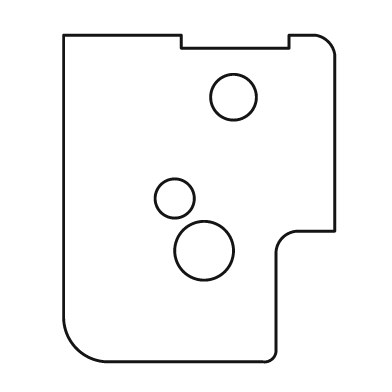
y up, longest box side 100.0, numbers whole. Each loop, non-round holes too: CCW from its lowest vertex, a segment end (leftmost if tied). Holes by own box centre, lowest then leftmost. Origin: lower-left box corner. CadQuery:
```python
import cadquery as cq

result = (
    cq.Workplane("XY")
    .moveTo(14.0, 0.0)
    .lineTo(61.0, 0.0)
    .threePointArc((64.0, 1.0), (65.0, 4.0))
    .lineTo(65.0, 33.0)
    .threePointArc((67.0, 38.0), (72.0, 40.0))
    .lineTo(83.0, 40.0)
    .lineTo(83.0, 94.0)
    .threePointArc((81.0, 98.0), (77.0, 100.0))
    .lineTo(69.0, 100.0)
    .lineTo(69.0, 96.0)
    .lineTo(36.0, 96.0)
    .lineTo(36.0, 100.0)
    .lineTo(0.0, 100.0)
    .lineTo(0.0, 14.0)
    .threePointArc((4.0, 4.0), (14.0, 0.0))
    .close()
    .moveTo(43.0, 34.0)
    .circle(9.0)
    .moveTo(34.0, 50.0)
    .circle(6.0)
    .moveTo(52.0, 81.0)
    .circle(7.0)
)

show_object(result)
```